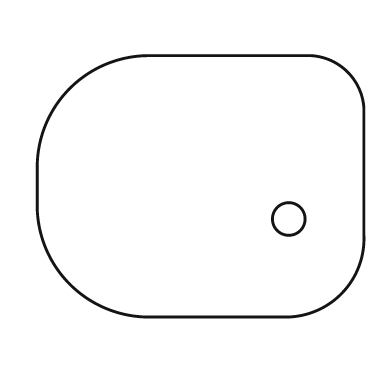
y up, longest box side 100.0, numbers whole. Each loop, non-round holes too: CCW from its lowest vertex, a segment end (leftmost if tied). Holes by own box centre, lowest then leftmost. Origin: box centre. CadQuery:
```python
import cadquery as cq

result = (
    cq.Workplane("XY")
    .moveTo(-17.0, -40.0)
    .lineTo(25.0, -40.0)
    .threePointArc((43.0, -33.0), (50.0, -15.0))
    .lineTo(50.0, 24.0)
    .threePointArc((45.0, 35.0), (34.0, 40.0))
    .lineTo(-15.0, 40.0)
    .threePointArc((-40.0, 30.0), (-50.0, 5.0))
    .lineTo(-50.0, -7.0)
    .threePointArc((-40.0, -30.0), (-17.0, -40.0))
    .close()
    .moveTo(27.0, -10.0)
    .circle(5.0)
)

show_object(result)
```